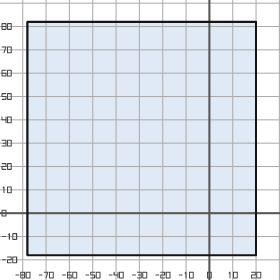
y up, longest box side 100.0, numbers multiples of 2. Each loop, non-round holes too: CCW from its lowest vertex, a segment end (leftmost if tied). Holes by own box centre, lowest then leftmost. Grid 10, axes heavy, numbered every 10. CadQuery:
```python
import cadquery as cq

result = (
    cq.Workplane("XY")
    .moveTo(-78.0, -18.0)
    .lineTo(20.0, -18.0)
    .lineTo(20.0, 82.0)
    .lineTo(-78.0, 82.0)
    .close()
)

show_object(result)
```